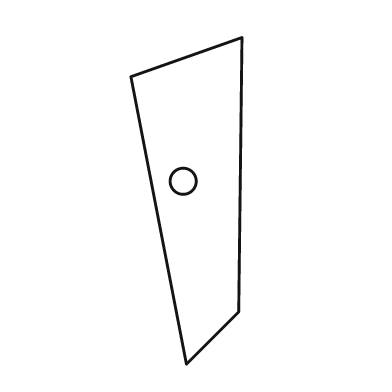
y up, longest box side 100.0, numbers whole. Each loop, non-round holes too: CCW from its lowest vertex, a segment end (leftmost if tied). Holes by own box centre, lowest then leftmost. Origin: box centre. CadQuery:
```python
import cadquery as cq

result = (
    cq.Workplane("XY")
    .moveTo(0.0, -50.0)
    .lineTo(16.0, -34.0)
    .lineTo(17.0, 50.0)
    .lineTo(-17.0, 38.0)
    .close()
    .moveTo(-1.0, 6.0)
    .circle(4.0)
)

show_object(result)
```